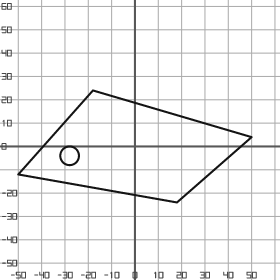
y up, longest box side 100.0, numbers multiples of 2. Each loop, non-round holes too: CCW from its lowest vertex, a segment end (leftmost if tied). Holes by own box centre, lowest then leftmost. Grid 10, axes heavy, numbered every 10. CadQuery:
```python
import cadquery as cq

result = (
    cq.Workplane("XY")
    .moveTo(18.0, -24.0)
    .lineTo(50.0, 4.0)
    .lineTo(-18.0, 24.0)
    .lineTo(-50.0, -12.0)
    .close()
    .moveTo(-28.0, -4.0)
    .circle(4.0)
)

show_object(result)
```